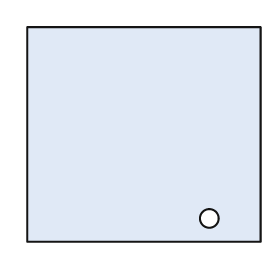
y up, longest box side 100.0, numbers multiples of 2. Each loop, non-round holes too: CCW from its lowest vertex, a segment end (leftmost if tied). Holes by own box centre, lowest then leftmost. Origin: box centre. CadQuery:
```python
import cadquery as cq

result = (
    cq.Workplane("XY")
    .moveTo(-50.0, -46.0)
    .lineTo(50.0, -46.0)
    .lineTo(50.0, 46.0)
    .lineTo(-50.0, 46.0)
    .close()
    .moveTo(28.0, -36.0)
    .circle(4.0)
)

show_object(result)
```